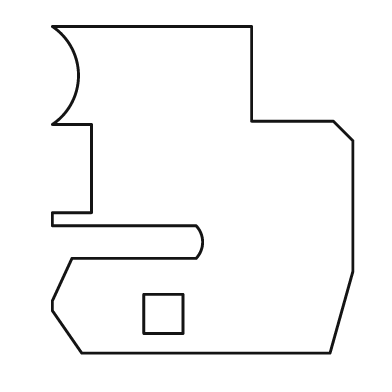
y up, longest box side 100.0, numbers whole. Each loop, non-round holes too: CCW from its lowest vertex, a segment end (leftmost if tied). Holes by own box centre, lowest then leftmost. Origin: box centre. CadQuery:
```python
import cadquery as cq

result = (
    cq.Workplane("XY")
    .moveTo(-37.0, -50.0)
    .lineTo(39.0, -50.0)
    .lineTo(46.0, -25.0)
    .lineTo(46.0, 15.0)
    .lineTo(40.0, 21.0)
    .lineTo(15.0, 21.0)
    .lineTo(15.0, 50.0)
    .lineTo(-46.0, 50.0)
    .threePointArc((-38.0, 35.0), (-46.0, 20.0))
    .lineTo(-34.0, 20.0)
    .lineTo(-34.0, -7.0)
    .lineTo(-46.0, -7.0)
    .lineTo(-46.0, -11.0)
    .lineTo(-2.0, -11.0)
    .threePointArc((0.0, -16.0), (-2.0, -21.0))
    .lineTo(-40.0, -21.0)
    .lineTo(-46.0, -34.0)
    .lineTo(-46.0, -37.0)
    .close()
    .moveTo(-18.0, -44.0)
    .lineTo(-6.0, -44.0)
    .lineTo(-6.0, -32.0)
    .lineTo(-18.0, -32.0)
    .close()
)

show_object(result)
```